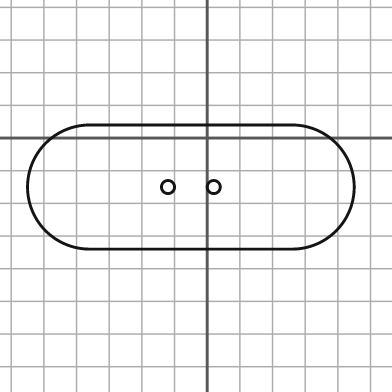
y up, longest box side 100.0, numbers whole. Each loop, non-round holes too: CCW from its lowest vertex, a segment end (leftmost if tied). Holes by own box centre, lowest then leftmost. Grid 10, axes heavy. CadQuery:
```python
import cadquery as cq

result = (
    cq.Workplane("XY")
    .moveTo(-36.0, -34.0)
    .lineTo(26.0, -34.0)
    .threePointArc((45.0, -15.0), (26.0, 4.0))
    .lineTo(-36.0, 4.0)
    .threePointArc((-55.0, -15.0), (-36.0, -34.0))
    .close()
    .moveTo(-12.0, -15.0)
    .circle(2.0)
    .moveTo(2.0, -15.0)
    .circle(2.0)
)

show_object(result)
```